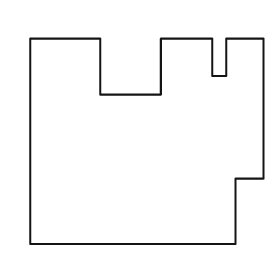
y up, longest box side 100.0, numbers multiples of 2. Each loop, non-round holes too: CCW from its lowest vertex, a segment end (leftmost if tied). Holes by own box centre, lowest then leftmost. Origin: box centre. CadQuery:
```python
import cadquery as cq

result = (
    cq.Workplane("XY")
    .moveTo(-50.0, -44.0)
    .lineTo(38.0, -44.0)
    .lineTo(38.0, -16.0)
    .lineTo(50.0, -16.0)
    .lineTo(50.0, 44.0)
    .lineTo(34.0, 44.0)
    .lineTo(34.0, 28.0)
    .lineTo(28.0, 28.0)
    .lineTo(28.0, 44.0)
    .lineTo(6.0, 44.0)
    .lineTo(6.0, 20.0)
    .lineTo(-20.0, 20.0)
    .lineTo(-20.0, 44.0)
    .lineTo(-50.0, 44.0)
    .close()
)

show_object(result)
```